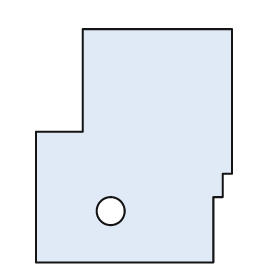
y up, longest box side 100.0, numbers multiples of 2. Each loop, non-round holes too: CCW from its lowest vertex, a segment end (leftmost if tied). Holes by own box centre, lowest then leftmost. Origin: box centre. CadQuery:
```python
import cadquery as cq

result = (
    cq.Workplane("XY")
    .moveTo(-42.0, -50.0)
    .lineTo(34.0, -50.0)
    .lineTo(34.0, -22.0)
    .lineTo(38.0, -22.0)
    .lineTo(38.0, -12.0)
    .lineTo(42.0, -12.0)
    .lineTo(42.0, 50.0)
    .lineTo(-22.0, 50.0)
    .lineTo(-22.0, 6.0)
    .lineTo(-42.0, 6.0)
    .close()
    .moveTo(-10.0, -28.0)
    .circle(6.0)
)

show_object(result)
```